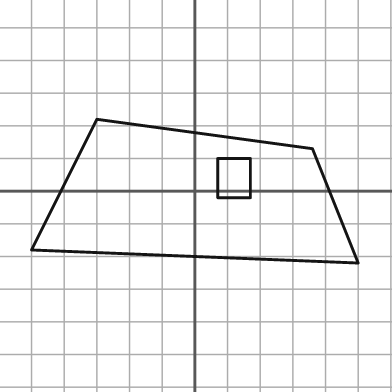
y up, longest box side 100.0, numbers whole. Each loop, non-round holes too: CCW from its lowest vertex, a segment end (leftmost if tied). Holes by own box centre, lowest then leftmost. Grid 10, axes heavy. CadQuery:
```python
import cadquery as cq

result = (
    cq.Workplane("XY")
    .moveTo(50.0, -22.0)
    .lineTo(36.0, 13.0)
    .lineTo(-30.0, 22.0)
    .lineTo(-50.0, -18.0)
    .close()
    .moveTo(7.0, -2.0)
    .lineTo(17.0, -2.0)
    .lineTo(17.0, 10.0)
    .lineTo(7.0, 10.0)
    .close()
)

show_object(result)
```